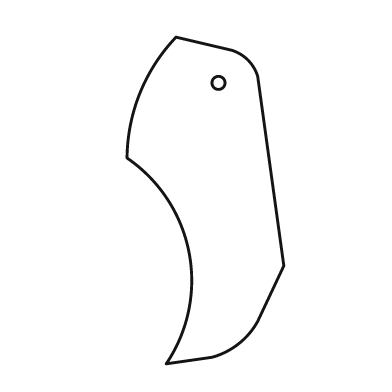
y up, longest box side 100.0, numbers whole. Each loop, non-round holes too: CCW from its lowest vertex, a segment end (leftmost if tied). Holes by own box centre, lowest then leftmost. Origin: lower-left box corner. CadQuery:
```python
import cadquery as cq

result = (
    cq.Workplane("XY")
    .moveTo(12.0, 0.0)
    .lineTo(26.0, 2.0)
    .threePointArc((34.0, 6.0), (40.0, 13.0))
    .lineTo(48.0, 30.0)
    .lineTo(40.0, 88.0)
    .threePointArc((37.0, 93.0), (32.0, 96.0))
    .lineTo(15.0, 100.0)
    .threePointArc((4.0, 83.0), (0.0, 63.0))
    .threePointArc((19.0, 34.0), (12.0, 0.0))
    .close()
    .moveTo(28.0, 86.0)
    .circle(2.0)
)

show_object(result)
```